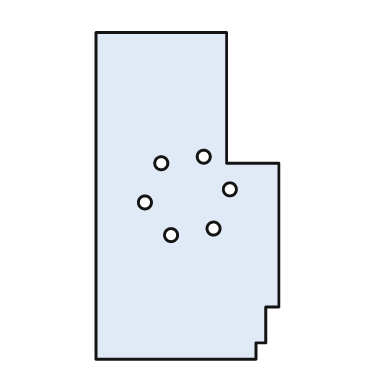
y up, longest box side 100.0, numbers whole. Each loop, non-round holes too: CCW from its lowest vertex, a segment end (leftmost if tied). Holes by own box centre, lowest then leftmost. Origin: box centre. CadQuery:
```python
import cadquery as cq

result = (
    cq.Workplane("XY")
    .moveTo(-28.0, -50.0)
    .lineTo(21.0, -50.0)
    .lineTo(21.0, -45.0)
    .lineTo(24.0, -45.0)
    .lineTo(24.0, -34.0)
    .lineTo(28.0, -34.0)
    .lineTo(28.0, 10.0)
    .lineTo(12.0, 10.0)
    .lineTo(12.0, 50.0)
    .lineTo(-28.0, 50.0)
    .close()
    .moveTo(-5.0, -12.0)
    .circle(2.0)
    .moveTo(8.0, -10.0)
    .circle(2.0)
    .moveTo(-13.0, -2.0)
    .circle(2.0)
    .moveTo(13.0, 2.0)
    .circle(2.0)
    .moveTo(-8.0, 10.0)
    .circle(2.0)
    .moveTo(5.0, 12.0)
    .circle(2.0)
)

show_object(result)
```